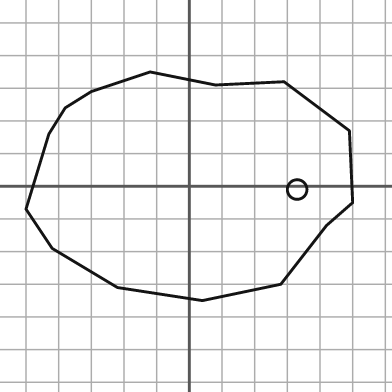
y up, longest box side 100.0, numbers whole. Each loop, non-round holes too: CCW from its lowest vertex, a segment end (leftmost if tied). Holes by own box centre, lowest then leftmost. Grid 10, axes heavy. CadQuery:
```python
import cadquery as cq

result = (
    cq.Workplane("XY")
    .moveTo(4.0, -35.0)
    .lineTo(28.0, -30.0)
    .lineTo(42.0, -12.0)
    .lineTo(50.0, -5.0)
    .lineTo(49.0, 17.0)
    .lineTo(29.0, 32.0)
    .lineTo(8.0, 31.0)
    .lineTo(-12.0, 35.0)
    .lineTo(-30.0, 29.0)
    .lineTo(-38.0, 24.0)
    .lineTo(-43.0, 16.0)
    .lineTo(-50.0, -7.0)
    .lineTo(-42.0, -19.0)
    .lineTo(-22.0, -31.0)
    .close()
    .moveTo(33.0, -1.0)
    .circle(3.0)
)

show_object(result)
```